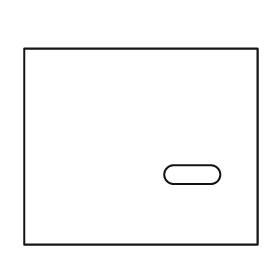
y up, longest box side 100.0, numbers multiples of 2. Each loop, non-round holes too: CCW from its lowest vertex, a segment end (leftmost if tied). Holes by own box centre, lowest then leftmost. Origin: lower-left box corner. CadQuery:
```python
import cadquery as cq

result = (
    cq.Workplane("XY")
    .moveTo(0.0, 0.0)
    .lineTo(100.0, 0.0)
    .lineTo(100.0, 84.0)
    .lineTo(0.0, 84.0)
    .close()
    .moveTo(64.0, 26.0)
    .lineTo(80.0, 26.0)
    .threePointArc((84.0, 30.0), (80.0, 34.0))
    .lineTo(64.0, 34.0)
    .threePointArc((60.0, 30.0), (64.0, 26.0))
    .close()
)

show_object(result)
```